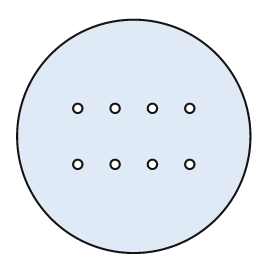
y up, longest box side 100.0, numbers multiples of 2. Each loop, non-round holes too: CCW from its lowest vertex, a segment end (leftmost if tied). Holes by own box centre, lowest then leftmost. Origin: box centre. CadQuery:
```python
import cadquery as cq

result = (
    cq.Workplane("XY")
    .moveTo(0.0, 0.0)
    .circle(50.0)
    .moveTo(-24.0, -12.0)
    .circle(2.0)
    .moveTo(-8.0, -12.0)
    .circle(2.0)
    .moveTo(8.0, -12.0)
    .circle(2.0)
    .moveTo(24.0, -12.0)
    .circle(2.0)
    .moveTo(-24.0, 12.0)
    .circle(2.0)
    .moveTo(-8.0, 12.0)
    .circle(2.0)
    .moveTo(8.0, 12.0)
    .circle(2.0)
    .moveTo(24.0, 12.0)
    .circle(2.0)
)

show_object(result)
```